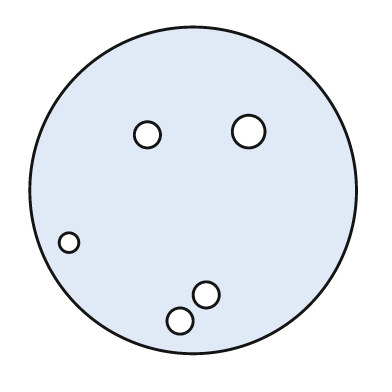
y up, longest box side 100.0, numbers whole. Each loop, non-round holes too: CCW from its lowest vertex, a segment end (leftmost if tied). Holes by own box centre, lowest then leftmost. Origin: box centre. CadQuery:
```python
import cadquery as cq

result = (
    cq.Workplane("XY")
    .moveTo(0.0, 0.0)
    .circle(50.0)
    .moveTo(-4.0, -40.0)
    .circle(4.0)
    .moveTo(4.0, -32.0)
    .circle(4.0)
    .moveTo(-38.0, -16.0)
    .circle(3.0)
    .moveTo(-14.0, 17.0)
    .circle(4.0)
    .moveTo(17.0, 18.0)
    .circle(5.0)
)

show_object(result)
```